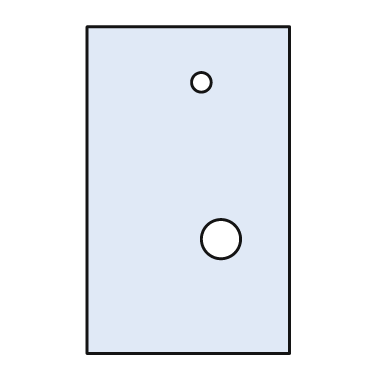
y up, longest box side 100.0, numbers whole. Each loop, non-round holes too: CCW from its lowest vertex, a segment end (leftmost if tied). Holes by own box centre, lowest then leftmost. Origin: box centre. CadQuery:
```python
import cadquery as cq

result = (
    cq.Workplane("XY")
    .moveTo(-31.0, -50.0)
    .lineTo(31.0, -50.0)
    .lineTo(31.0, 50.0)
    .lineTo(-31.0, 50.0)
    .close()
    .moveTo(10.0, -15.0)
    .circle(6.0)
    .moveTo(4.0, 33.0)
    .circle(3.0)
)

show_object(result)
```